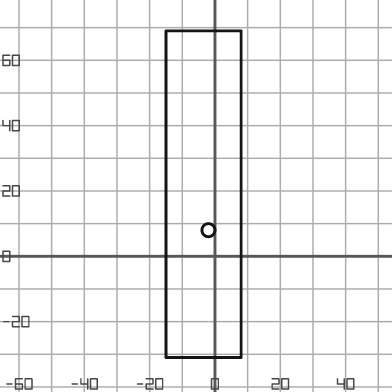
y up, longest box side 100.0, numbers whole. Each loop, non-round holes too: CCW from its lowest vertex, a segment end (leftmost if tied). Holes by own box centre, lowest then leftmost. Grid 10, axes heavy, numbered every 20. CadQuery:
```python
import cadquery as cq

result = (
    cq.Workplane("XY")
    .moveTo(-15.0, -31.0)
    .lineTo(8.0, -31.0)
    .lineTo(8.0, 69.0)
    .lineTo(-15.0, 69.0)
    .close()
    .moveTo(-2.0, 8.0)
    .circle(2.0)
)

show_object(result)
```